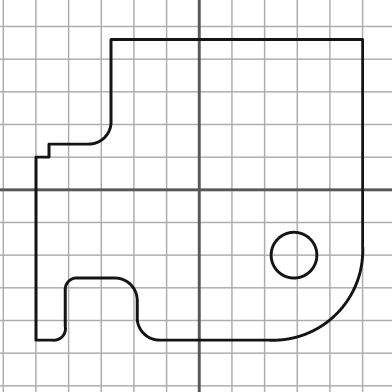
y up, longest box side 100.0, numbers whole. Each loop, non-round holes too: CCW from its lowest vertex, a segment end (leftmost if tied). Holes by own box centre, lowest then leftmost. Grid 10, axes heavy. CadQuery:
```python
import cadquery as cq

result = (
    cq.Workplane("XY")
    .moveTo(-50.0, -46.0)
    .lineTo(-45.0, -46.0)
    .threePointArc((-42.0, -45.0), (-41.0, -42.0))
    .lineTo(-41.0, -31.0)
    .threePointArc((-40.0, -28.0), (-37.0, -27.0))
    .lineTo(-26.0, -27.0)
    .threePointArc((-21.0, -29.0), (-19.0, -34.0))
    .lineTo(-19.0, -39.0)
    .threePointArc((-17.0, -44.0), (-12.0, -46.0))
    .lineTo(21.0, -46.0)
    .threePointArc((42.0, -38.0), (50.0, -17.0))
    .lineTo(50.0, 46.0)
    .lineTo(-27.0, 46.0)
    .lineTo(-27.0, 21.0)
    .threePointArc((-29.0, 16.0), (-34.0, 14.0))
    .lineTo(-46.0, 14.0)
    .lineTo(-46.0, 10.0)
    .lineTo(-50.0, 10.0)
    .close()
    .moveTo(29.0, -20.0)
    .circle(7.0)
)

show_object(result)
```